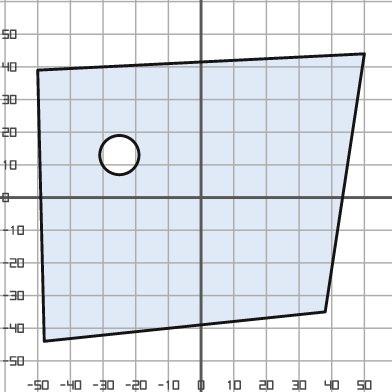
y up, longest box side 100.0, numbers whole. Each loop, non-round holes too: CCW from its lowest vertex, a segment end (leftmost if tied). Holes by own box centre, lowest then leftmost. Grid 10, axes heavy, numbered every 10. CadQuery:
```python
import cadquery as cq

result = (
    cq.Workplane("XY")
    .moveTo(-48.0, -44.0)
    .lineTo(38.0, -35.0)
    .lineTo(50.0, 44.0)
    .lineTo(-50.0, 39.0)
    .close()
    .moveTo(-25.0, 13.0)
    .circle(6.0)
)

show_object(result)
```